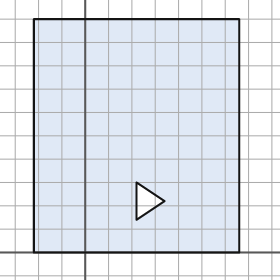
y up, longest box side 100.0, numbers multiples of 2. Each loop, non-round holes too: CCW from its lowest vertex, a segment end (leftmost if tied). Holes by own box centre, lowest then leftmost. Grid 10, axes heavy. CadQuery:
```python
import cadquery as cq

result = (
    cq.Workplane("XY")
    .moveTo(-22.0, 0.0)
    .lineTo(66.0, 0.0)
    .lineTo(66.0, 100.0)
    .lineTo(-22.0, 100.0)
    .close()
    .moveTo(22.0, 14.0)
    .lineTo(34.0, 22.0)
    .lineTo(22.0, 30.0)
    .close()
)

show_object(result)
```